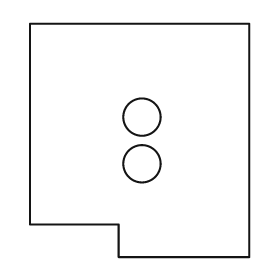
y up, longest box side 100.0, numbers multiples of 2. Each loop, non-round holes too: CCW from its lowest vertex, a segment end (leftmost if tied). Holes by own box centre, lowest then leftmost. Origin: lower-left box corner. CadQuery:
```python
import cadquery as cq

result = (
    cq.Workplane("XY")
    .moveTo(38.0, 0.0)
    .lineTo(94.0, 0.0)
    .lineTo(94.0, 100.0)
    .lineTo(0.0, 100.0)
    .lineTo(0.0, 14.0)
    .lineTo(38.0, 14.0)
    .close()
    .moveTo(48.0, 40.0)
    .circle(8.0)
    .moveTo(48.0, 60.0)
    .circle(8.0)
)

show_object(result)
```